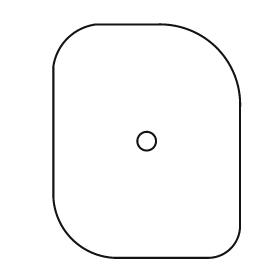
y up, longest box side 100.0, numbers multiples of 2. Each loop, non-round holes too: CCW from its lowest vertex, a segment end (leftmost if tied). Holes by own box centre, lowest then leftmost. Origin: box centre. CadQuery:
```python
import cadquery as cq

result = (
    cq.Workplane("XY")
    .moveTo(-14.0, -50.0)
    .lineTo(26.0, -50.0)
    .threePointArc((36.0, -46.0), (40.0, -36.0))
    .lineTo(40.0, 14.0)
    .threePointArc((30.0, 40.0), (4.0, 50.0))
    .lineTo(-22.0, 50.0)
    .threePointArc((-34.0, 44.0), (-40.0, 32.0))
    .lineTo(-40.0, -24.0)
    .threePointArc((-32.0, -42.0), (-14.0, -50.0))
    .close()
    .moveTo(0.0, 0.0)
    .circle(4.0)
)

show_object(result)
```